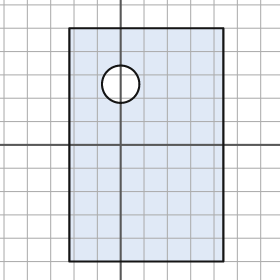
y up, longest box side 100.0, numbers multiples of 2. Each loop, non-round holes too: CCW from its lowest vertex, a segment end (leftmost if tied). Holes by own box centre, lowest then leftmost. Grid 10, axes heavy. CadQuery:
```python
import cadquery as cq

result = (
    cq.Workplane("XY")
    .moveTo(-22.0, -50.0)
    .lineTo(44.0, -50.0)
    .lineTo(44.0, 50.0)
    .lineTo(-22.0, 50.0)
    .close()
    .moveTo(0.0, 26.0)
    .circle(8.0)
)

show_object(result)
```